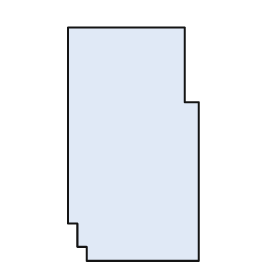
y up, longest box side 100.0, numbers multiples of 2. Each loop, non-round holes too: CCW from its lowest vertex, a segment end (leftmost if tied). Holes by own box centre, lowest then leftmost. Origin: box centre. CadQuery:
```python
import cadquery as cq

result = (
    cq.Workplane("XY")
    .moveTo(-20.0, -50.0)
    .lineTo(28.0, -50.0)
    .lineTo(28.0, 18.0)
    .lineTo(22.0, 18.0)
    .lineTo(22.0, 50.0)
    .lineTo(-28.0, 50.0)
    .lineTo(-28.0, -34.0)
    .lineTo(-24.0, -34.0)
    .lineTo(-24.0, -44.0)
    .lineTo(-20.0, -44.0)
    .close()
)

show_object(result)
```